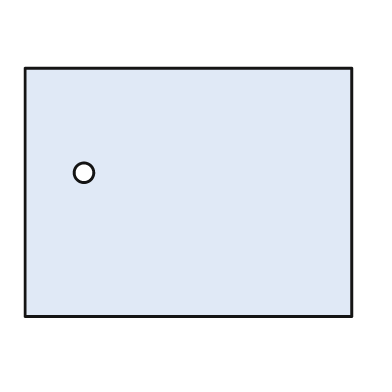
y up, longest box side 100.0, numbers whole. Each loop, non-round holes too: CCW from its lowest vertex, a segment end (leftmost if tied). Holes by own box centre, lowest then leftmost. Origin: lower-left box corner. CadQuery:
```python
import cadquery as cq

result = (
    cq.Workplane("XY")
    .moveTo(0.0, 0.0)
    .lineTo(100.0, 0.0)
    .lineTo(100.0, 76.0)
    .lineTo(0.0, 76.0)
    .close()
    .moveTo(18.0, 44.0)
    .circle(3.0)
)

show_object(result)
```